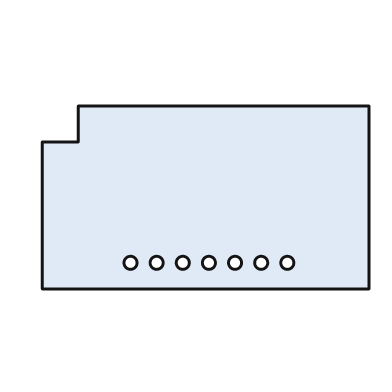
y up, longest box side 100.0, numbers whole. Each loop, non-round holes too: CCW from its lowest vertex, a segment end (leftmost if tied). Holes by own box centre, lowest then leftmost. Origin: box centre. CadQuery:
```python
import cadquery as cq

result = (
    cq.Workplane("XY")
    .moveTo(-50.0, -28.0)
    .lineTo(50.0, -28.0)
    .lineTo(50.0, 28.0)
    .lineTo(-39.0, 28.0)
    .lineTo(-39.0, 17.0)
    .lineTo(-50.0, 17.0)
    .close()
    .moveTo(-23.0, -20.0)
    .circle(2.0)
    .moveTo(-15.0, -20.0)
    .circle(2.0)
    .moveTo(-7.0, -20.0)
    .circle(2.0)
    .moveTo(1.0, -20.0)
    .circle(2.0)
    .moveTo(9.0, -20.0)
    .circle(2.0)
    .moveTo(17.0, -20.0)
    .circle(2.0)
    .moveTo(25.0, -20.0)
    .circle(2.0)
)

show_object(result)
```